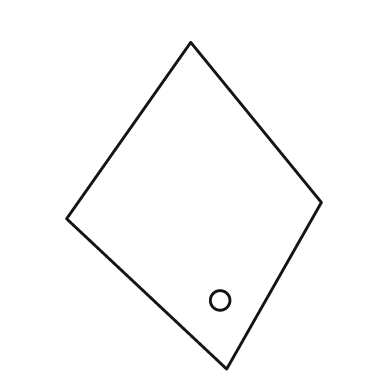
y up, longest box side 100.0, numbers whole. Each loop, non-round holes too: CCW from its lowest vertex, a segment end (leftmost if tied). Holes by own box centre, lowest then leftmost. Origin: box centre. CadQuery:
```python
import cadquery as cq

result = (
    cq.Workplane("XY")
    .moveTo(10.0, -50.0)
    .lineTo(39.0, 1.0)
    .lineTo(-1.0, 50.0)
    .lineTo(-39.0, -4.0)
    .close()
    .moveTo(8.0, -29.0)
    .circle(3.0)
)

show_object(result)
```